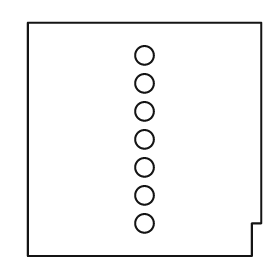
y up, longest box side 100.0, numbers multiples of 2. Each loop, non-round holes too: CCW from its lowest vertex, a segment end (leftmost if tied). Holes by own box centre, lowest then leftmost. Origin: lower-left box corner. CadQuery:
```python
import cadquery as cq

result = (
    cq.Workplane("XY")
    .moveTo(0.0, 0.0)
    .lineTo(96.0, 0.0)
    .lineTo(96.0, 14.0)
    .lineTo(100.0, 14.0)
    .lineTo(100.0, 100.0)
    .lineTo(0.0, 100.0)
    .close()
    .moveTo(50.0, 14.0)
    .circle(4.0)
    .moveTo(50.0, 26.0)
    .circle(4.0)
    .moveTo(50.0, 38.0)
    .circle(4.0)
    .moveTo(50.0, 50.0)
    .circle(4.0)
    .moveTo(50.0, 62.0)
    .circle(4.0)
    .moveTo(50.0, 74.0)
    .circle(4.0)
    .moveTo(50.0, 86.0)
    .circle(4.0)
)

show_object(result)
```